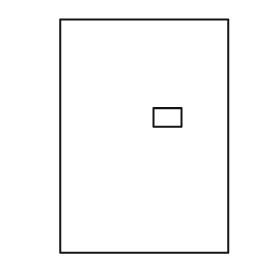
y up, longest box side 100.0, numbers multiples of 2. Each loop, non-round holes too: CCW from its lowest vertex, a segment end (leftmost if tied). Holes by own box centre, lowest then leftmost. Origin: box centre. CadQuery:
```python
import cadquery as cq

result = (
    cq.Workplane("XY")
    .moveTo(-36.0, -50.0)
    .lineTo(36.0, -50.0)
    .lineTo(36.0, 50.0)
    .lineTo(-36.0, 50.0)
    .close()
    .moveTo(4.0, 4.0)
    .lineTo(16.0, 4.0)
    .lineTo(16.0, 12.0)
    .lineTo(4.0, 12.0)
    .close()
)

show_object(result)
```